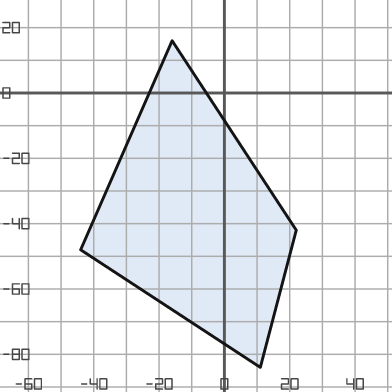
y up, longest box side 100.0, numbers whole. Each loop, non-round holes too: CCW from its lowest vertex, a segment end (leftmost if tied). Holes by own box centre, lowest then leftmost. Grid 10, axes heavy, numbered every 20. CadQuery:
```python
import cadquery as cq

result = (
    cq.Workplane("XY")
    .moveTo(11.0, -84.0)
    .lineTo(22.0, -42.0)
    .lineTo(-16.0, 16.0)
    .lineTo(-44.0, -48.0)
    .close()
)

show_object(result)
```